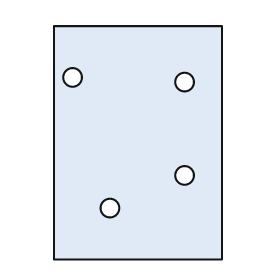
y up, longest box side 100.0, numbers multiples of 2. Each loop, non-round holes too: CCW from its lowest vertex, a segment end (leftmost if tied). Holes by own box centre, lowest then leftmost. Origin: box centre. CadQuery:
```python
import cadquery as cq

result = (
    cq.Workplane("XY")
    .moveTo(-36.0, -50.0)
    .lineTo(36.0, -50.0)
    .lineTo(36.0, 50.0)
    .lineTo(-36.0, 50.0)
    .close()
    .moveTo(-12.0, -28.0)
    .circle(4.0)
    .moveTo(20.0, -14.0)
    .circle(4.0)
    .moveTo(20.0, 26.0)
    .circle(4.0)
    .moveTo(-28.0, 28.0)
    .circle(4.0)
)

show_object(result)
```